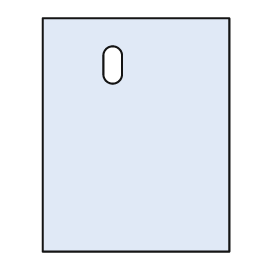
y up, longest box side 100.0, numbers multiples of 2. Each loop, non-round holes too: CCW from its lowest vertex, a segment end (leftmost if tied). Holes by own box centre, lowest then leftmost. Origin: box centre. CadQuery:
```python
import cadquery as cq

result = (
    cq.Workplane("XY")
    .moveTo(-40.0, -50.0)
    .lineTo(40.0, -50.0)
    .lineTo(40.0, 50.0)
    .lineTo(-40.0, 50.0)
    .close()
    .moveTo(-14.0, 26.0)
    .threePointArc((-10.0, 22.0), (-6.0, 26.0))
    .lineTo(-6.0, 34.0)
    .threePointArc((-10.0, 38.0), (-14.0, 34.0))
    .close()
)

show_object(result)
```